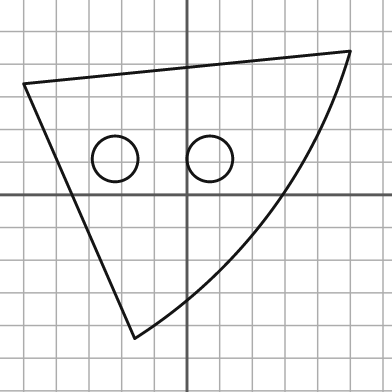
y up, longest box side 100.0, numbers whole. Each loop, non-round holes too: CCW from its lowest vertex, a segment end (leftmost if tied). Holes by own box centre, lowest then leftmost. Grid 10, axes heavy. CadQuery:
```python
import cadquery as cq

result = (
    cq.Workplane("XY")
    .moveTo(-16.0, -44.0)
    .threePointArc((25.0, -6.0), (50.0, 44.0))
    .lineTo(-50.0, 34.0)
    .close()
    .moveTo(-22.0, 11.0)
    .circle(7.0)
    .moveTo(7.0, 11.0)
    .circle(7.0)
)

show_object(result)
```